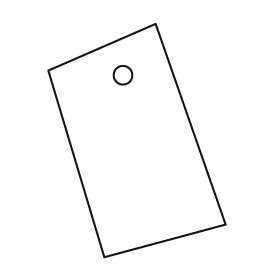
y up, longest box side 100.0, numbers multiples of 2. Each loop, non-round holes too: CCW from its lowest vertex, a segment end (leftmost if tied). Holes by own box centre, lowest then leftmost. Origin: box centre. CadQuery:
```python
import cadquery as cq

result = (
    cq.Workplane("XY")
    .moveTo(-14.0, -50.0)
    .lineTo(38.0, -36.0)
    .lineTo(8.0, 50.0)
    .lineTo(-38.0, 30.0)
    .close()
    .moveTo(-6.0, 28.0)
    .circle(4.0)
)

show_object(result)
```